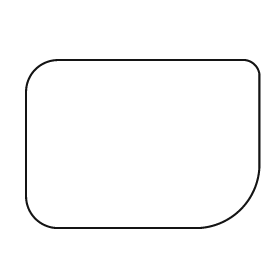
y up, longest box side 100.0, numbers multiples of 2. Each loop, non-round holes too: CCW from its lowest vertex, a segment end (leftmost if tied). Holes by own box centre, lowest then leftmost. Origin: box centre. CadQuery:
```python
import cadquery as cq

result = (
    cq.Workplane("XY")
    .moveTo(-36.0, -36.0)
    .lineTo(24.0, -36.0)
    .threePointArc((42.0, -28.0), (50.0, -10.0))
    .lineTo(50.0, 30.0)
    .threePointArc((48.0, 34.0), (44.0, 36.0))
    .lineTo(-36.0, 36.0)
    .threePointArc((-46.0, 32.0), (-50.0, 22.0))
    .lineTo(-50.0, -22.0)
    .threePointArc((-46.0, -32.0), (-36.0, -36.0))
    .close()
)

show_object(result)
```